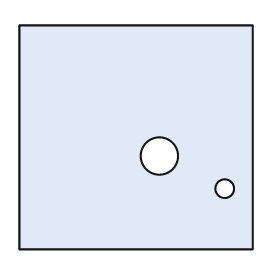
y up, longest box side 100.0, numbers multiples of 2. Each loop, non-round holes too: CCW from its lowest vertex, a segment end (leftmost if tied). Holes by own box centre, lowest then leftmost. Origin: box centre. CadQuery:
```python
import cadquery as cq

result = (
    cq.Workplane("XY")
    .moveTo(-50.0, -48.0)
    .lineTo(50.0, -48.0)
    .lineTo(50.0, 48.0)
    .lineTo(-50.0, 48.0)
    .close()
    .moveTo(38.0, -22.0)
    .circle(4.0)
    .moveTo(10.0, -8.0)
    .circle(8.0)
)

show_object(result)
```